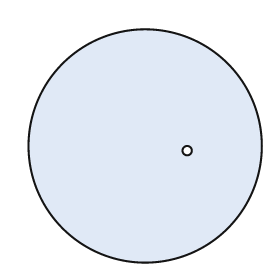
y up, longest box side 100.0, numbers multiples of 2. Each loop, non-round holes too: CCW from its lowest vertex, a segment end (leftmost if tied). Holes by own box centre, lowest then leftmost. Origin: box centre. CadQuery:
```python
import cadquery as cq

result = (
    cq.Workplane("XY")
    .moveTo(0.0, 0.0)
    .circle(50.0)
    .moveTo(18.0, -2.0)
    .circle(2.0)
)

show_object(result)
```